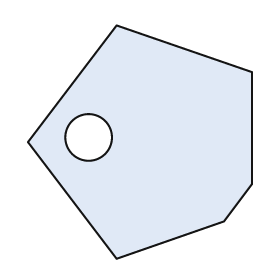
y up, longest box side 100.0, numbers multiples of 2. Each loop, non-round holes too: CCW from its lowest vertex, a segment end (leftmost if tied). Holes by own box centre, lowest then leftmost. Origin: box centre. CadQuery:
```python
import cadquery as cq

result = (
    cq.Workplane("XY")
    .moveTo(-10.0, -50.0)
    .lineTo(36.0, -34.0)
    .lineTo(48.0, -18.0)
    .lineTo(48.0, 30.0)
    .lineTo(-10.0, 50.0)
    .lineTo(-48.0, 0.0)
    .close()
    .moveTo(-22.0, 2.0)
    .circle(10.0)
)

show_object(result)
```